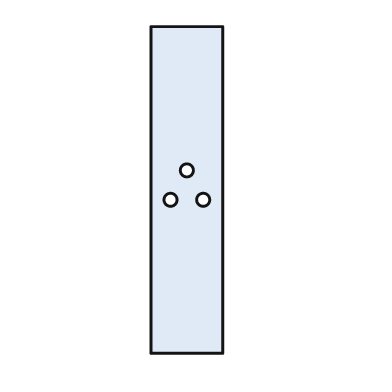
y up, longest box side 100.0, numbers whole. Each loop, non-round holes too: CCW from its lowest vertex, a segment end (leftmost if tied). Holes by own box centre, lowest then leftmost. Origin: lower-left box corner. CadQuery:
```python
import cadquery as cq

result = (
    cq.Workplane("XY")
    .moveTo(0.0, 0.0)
    .lineTo(22.0, 0.0)
    .lineTo(22.0, 100.0)
    .lineTo(0.0, 100.0)
    .close()
    .moveTo(6.0, 47.0)
    .circle(2.0)
    .moveTo(16.0, 47.0)
    .circle(2.0)
    .moveTo(11.0, 56.0)
    .circle(2.0)
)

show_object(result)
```